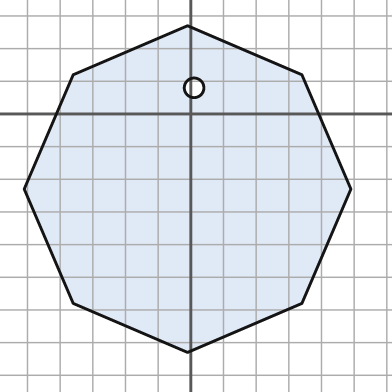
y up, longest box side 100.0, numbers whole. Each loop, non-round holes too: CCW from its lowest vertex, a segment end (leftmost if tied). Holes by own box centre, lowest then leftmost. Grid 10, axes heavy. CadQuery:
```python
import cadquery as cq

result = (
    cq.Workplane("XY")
    .moveTo(-1.0, -73.0)
    .lineTo(34.0, -58.0)
    .lineTo(49.0, -23.0)
    .lineTo(34.0, 12.0)
    .lineTo(-1.0, 27.0)
    .lineTo(-36.0, 12.0)
    .lineTo(-51.0, -23.0)
    .lineTo(-36.0, -58.0)
    .close()
    .moveTo(1.0, 8.0)
    .circle(3.0)
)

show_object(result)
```